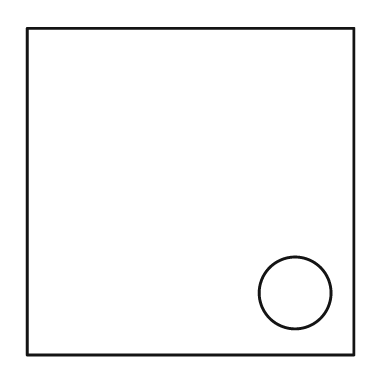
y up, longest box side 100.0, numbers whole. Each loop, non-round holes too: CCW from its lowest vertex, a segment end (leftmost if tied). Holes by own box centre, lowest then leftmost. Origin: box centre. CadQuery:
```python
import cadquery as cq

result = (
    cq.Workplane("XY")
    .moveTo(-50.0, -50.0)
    .lineTo(50.0, -50.0)
    .lineTo(50.0, 50.0)
    .lineTo(-50.0, 50.0)
    .close()
    .moveTo(32.0, -31.0)
    .circle(11.0)
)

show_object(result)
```